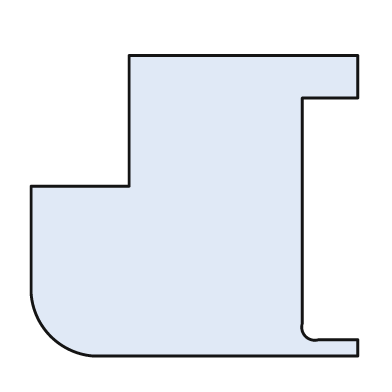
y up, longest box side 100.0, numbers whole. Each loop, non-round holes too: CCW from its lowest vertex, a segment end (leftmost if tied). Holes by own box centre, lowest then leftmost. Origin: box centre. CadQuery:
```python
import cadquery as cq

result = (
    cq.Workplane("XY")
    .moveTo(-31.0, -46.0)
    .lineTo(50.0, -46.0)
    .lineTo(50.0, -41.0)
    .lineTo(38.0, -41.0)
    .threePointArc((34.0, -40.0), (33.0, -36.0))
    .lineTo(33.0, 33.0)
    .lineTo(50.0, 33.0)
    .lineTo(50.0, 46.0)
    .lineTo(-20.0, 46.0)
    .lineTo(-20.0, 6.0)
    .lineTo(-50.0, 6.0)
    .lineTo(-50.0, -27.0)
    .threePointArc((-44.0, -40.0), (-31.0, -46.0))
    .close()
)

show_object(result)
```